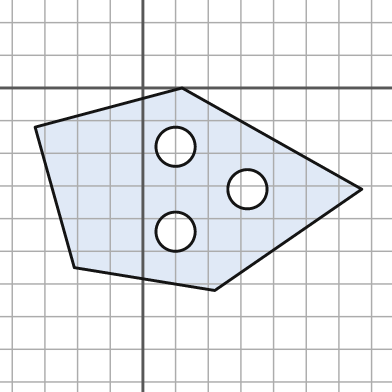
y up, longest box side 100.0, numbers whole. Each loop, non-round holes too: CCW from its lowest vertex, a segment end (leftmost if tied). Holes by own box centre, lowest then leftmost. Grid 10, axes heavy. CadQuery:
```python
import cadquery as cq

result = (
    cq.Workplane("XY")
    .moveTo(22.0, -62.0)
    .lineTo(67.0, -31.0)
    .lineTo(12.0, 0.0)
    .lineTo(-33.0, -12.0)
    .lineTo(-21.0, -55.0)
    .close()
    .moveTo(10.0, -44.0)
    .circle(6.0)
    .moveTo(32.0, -31.0)
    .circle(6.0)
    .moveTo(10.0, -18.0)
    .circle(6.0)
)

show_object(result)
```